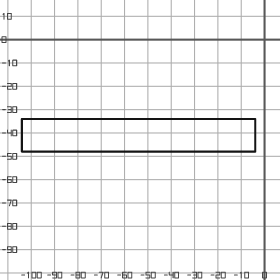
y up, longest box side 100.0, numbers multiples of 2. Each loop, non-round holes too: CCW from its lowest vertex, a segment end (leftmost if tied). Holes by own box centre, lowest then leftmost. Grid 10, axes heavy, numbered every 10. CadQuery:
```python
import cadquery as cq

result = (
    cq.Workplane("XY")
    .moveTo(-104.0, -48.0)
    .lineTo(-4.0, -48.0)
    .lineTo(-4.0, -34.0)
    .lineTo(-104.0, -34.0)
    .close()
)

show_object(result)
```